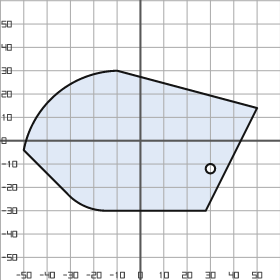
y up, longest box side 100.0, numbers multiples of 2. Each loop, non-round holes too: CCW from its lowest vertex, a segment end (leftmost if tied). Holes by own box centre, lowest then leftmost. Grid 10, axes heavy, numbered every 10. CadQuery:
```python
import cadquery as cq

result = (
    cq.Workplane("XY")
    .moveTo(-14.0, -30.0)
    .lineTo(28.0, -30.0)
    .lineTo(50.0, 14.0)
    .lineTo(-10.0, 30.0)
    .threePointArc((-36.0, 20.0), (-50.0, -4.0))
    .lineTo(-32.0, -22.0)
    .threePointArc((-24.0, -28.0), (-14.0, -30.0))
    .close()
    .moveTo(30.0, -12.0)
    .circle(2.0)
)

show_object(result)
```